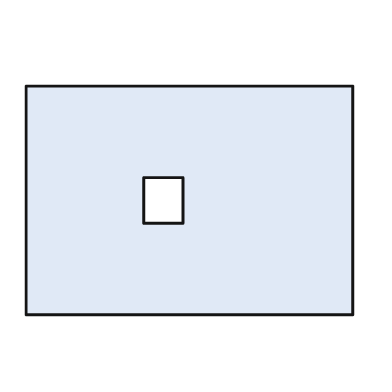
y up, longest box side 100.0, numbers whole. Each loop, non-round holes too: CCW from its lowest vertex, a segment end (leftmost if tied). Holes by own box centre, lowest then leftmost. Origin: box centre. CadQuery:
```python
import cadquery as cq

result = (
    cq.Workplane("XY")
    .moveTo(-50.0, -35.0)
    .lineTo(50.0, -35.0)
    .lineTo(50.0, 35.0)
    .lineTo(-50.0, 35.0)
    .close()
    .moveTo(-14.0, -7.0)
    .lineTo(-2.0, -7.0)
    .lineTo(-2.0, 7.0)
    .lineTo(-14.0, 7.0)
    .close()
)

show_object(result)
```